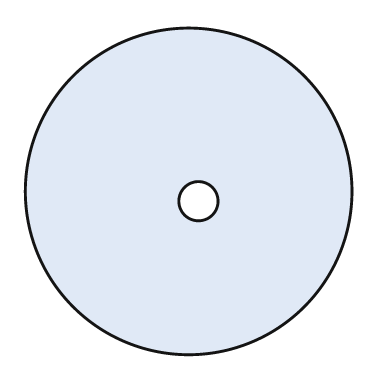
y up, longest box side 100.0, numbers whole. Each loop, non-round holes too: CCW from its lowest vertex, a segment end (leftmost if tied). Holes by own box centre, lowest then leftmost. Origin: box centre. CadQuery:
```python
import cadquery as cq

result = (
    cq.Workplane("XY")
    .moveTo(0.0, 0.0)
    .circle(50.0)
    .moveTo(3.0, -3.0)
    .circle(6.0)
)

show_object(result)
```